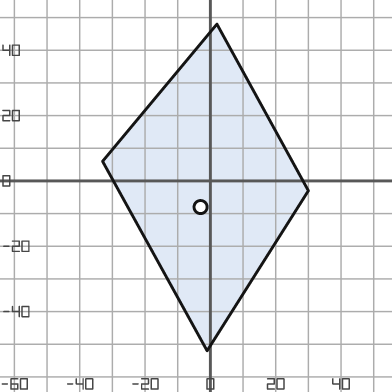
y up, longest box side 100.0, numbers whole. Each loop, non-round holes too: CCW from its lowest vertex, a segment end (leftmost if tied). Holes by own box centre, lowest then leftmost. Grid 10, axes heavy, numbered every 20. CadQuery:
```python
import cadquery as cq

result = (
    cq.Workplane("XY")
    .moveTo(-1.0, -52.0)
    .lineTo(30.0, -3.0)
    .lineTo(2.0, 48.0)
    .lineTo(-33.0, 6.0)
    .close()
    .moveTo(-3.0, -8.0)
    .circle(2.0)
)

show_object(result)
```